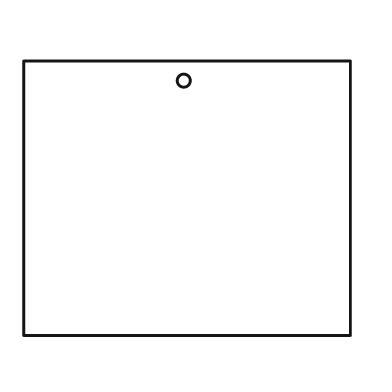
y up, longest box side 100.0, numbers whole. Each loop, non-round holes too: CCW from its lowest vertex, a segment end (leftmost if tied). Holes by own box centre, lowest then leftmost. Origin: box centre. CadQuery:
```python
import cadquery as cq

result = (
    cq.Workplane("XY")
    .moveTo(-50.0, -42.0)
    .lineTo(50.0, -42.0)
    .lineTo(50.0, 42.0)
    .lineTo(-50.0, 42.0)
    .close()
    .moveTo(-1.0, 36.0)
    .circle(2.0)
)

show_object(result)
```